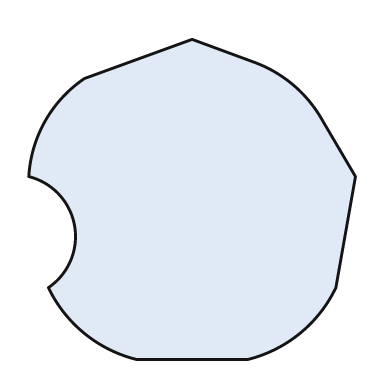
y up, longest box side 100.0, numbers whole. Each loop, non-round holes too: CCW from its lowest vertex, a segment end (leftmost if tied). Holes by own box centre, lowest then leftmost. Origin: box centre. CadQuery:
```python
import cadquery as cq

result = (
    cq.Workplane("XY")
    .moveTo(-17.0, -49.0)
    .lineTo(17.0, -49.0)
    .threePointArc((33.0, -41.0), (44.0, -27.0))
    .lineTo(50.0, 7.0)
    .lineTo(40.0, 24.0)
    .threePointArc((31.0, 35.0), (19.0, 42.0))
    .lineTo(0.0, 49.0)
    .lineTo(-33.0, 37.0)
    .threePointArc((-45.0, 24.0), (-50.0, 7.0))
    .threePointArc((-36.0, -8.0), (-44.0, -27.0))
    .threePointArc((-33.0, -41.0), (-17.0, -49.0))
    .close()
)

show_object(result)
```